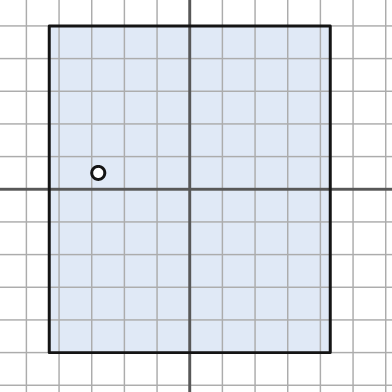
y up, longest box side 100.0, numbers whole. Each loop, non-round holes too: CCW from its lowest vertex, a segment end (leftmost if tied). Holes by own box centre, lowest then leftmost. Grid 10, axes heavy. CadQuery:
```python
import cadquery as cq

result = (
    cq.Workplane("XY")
    .moveTo(-43.0, -50.0)
    .lineTo(43.0, -50.0)
    .lineTo(43.0, 50.0)
    .lineTo(-43.0, 50.0)
    .close()
    .moveTo(-28.0, 5.0)
    .circle(2.0)
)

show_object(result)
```